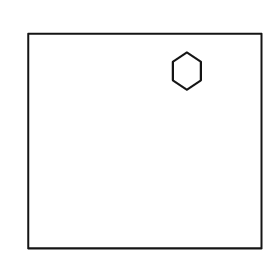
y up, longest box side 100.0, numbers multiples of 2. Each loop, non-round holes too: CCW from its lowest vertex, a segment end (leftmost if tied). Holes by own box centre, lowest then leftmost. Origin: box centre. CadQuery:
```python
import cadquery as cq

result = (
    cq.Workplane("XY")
    .moveTo(-50.0, -46.0)
    .lineTo(50.0, -46.0)
    .lineTo(50.0, 46.0)
    .lineTo(-50.0, 46.0)
    .close()
    .moveTo(18.0, 22.0)
    .lineTo(24.0, 26.0)
    .lineTo(24.0, 34.0)
    .lineTo(18.0, 38.0)
    .lineTo(12.0, 34.0)
    .lineTo(12.0, 26.0)
    .close()
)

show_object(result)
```